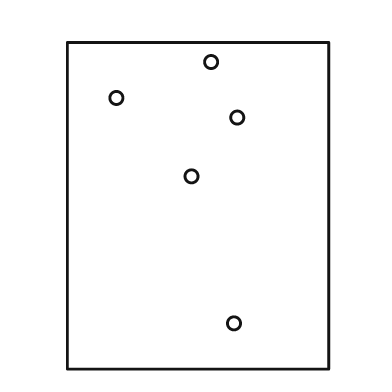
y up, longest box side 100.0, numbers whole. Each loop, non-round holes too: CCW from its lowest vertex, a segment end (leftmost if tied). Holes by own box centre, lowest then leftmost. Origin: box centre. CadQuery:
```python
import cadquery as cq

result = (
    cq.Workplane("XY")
    .moveTo(-40.0, -50.0)
    .lineTo(40.0, -50.0)
    .lineTo(40.0, 50.0)
    .lineTo(-40.0, 50.0)
    .close()
    .moveTo(11.0, -36.0)
    .circle(2.0)
    .moveTo(-2.0, 9.0)
    .circle(2.0)
    .moveTo(12.0, 27.0)
    .circle(2.0)
    .moveTo(-25.0, 33.0)
    .circle(2.0)
    .moveTo(4.0, 44.0)
    .circle(2.0)
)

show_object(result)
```